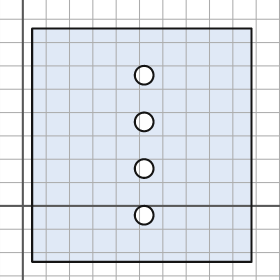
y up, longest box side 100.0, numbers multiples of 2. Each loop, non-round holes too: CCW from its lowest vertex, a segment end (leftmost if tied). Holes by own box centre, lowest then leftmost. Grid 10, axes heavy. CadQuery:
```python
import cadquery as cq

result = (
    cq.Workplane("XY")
    .moveTo(4.0, -24.0)
    .lineTo(98.0, -24.0)
    .lineTo(98.0, 76.0)
    .lineTo(4.0, 76.0)
    .close()
    .moveTo(52.0, -4.0)
    .circle(4.0)
    .moveTo(52.0, 16.0)
    .circle(4.0)
    .moveTo(52.0, 36.0)
    .circle(4.0)
    .moveTo(52.0, 56.0)
    .circle(4.0)
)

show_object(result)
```